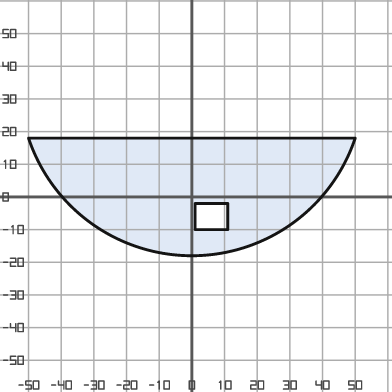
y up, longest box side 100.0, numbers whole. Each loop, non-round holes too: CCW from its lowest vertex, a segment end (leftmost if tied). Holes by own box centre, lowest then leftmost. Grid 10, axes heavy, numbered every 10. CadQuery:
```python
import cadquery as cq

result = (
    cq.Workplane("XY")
    .moveTo(-50.0, 18.0)
    .threePointArc((0.0, -18.0), (50.0, 18.0))
    .close()
    .moveTo(1.0, -10.0)
    .lineTo(11.0, -10.0)
    .lineTo(11.0, -2.0)
    .lineTo(1.0, -2.0)
    .close()
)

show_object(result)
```